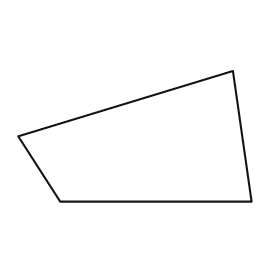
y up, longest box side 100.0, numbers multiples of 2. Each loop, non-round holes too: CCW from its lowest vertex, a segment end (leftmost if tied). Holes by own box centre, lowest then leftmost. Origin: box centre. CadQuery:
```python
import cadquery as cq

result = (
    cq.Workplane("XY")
    .moveTo(-32.0, -28.0)
    .lineTo(50.0, -28.0)
    .lineTo(42.0, 28.0)
    .lineTo(-50.0, 0.0)
    .close()
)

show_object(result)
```